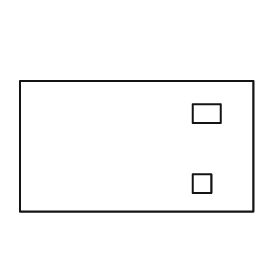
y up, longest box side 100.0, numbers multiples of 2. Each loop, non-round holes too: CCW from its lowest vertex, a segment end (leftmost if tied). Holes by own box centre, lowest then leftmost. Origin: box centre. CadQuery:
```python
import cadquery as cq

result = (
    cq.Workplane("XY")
    .moveTo(-50.0, -28.0)
    .lineTo(50.0, -28.0)
    .lineTo(50.0, 28.0)
    .lineTo(-50.0, 28.0)
    .close()
    .moveTo(24.0, -20.0)
    .lineTo(32.0, -20.0)
    .lineTo(32.0, -12.0)
    .lineTo(24.0, -12.0)
    .close()
    .moveTo(24.0, 10.0)
    .lineTo(36.0, 10.0)
    .lineTo(36.0, 18.0)
    .lineTo(24.0, 18.0)
    .close()
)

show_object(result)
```